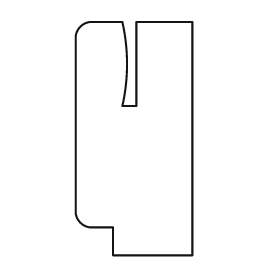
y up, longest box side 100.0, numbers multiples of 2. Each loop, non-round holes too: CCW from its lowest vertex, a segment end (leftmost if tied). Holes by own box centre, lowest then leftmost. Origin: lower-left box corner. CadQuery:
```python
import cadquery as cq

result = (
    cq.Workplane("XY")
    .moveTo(16.0, 0.0)
    .lineTo(50.0, 0.0)
    .lineTo(50.0, 100.0)
    .lineTo(26.0, 100.0)
    .lineTo(26.0, 64.0)
    .lineTo(20.0, 64.0)
    .threePointArc((22.0, 82.0), (20.0, 100.0))
    .lineTo(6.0, 100.0)
    .threePointArc((2.0, 98.0), (0.0, 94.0))
    .lineTo(0.0, 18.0)
    .threePointArc((2.0, 14.0), (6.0, 12.0))
    .lineTo(16.0, 12.0)
    .close()
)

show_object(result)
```